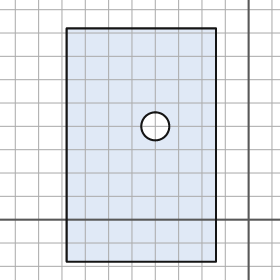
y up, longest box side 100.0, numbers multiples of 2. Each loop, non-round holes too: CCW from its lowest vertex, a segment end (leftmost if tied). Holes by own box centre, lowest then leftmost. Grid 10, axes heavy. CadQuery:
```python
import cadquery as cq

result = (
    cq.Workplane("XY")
    .moveTo(-78.0, -18.0)
    .lineTo(-14.0, -18.0)
    .lineTo(-14.0, 82.0)
    .lineTo(-78.0, 82.0)
    .close()
    .moveTo(-40.0, 40.0)
    .circle(6.0)
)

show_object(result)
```